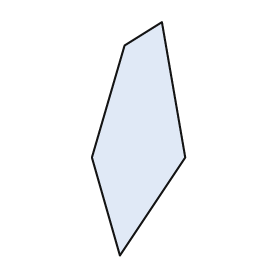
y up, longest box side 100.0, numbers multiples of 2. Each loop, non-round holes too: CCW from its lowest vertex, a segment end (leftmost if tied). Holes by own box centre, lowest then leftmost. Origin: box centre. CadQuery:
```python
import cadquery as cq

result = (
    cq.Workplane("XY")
    .moveTo(-8.0, -50.0)
    .lineTo(20.0, -8.0)
    .lineTo(10.0, 50.0)
    .lineTo(-6.0, 40.0)
    .lineTo(-20.0, -8.0)
    .close()
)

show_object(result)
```